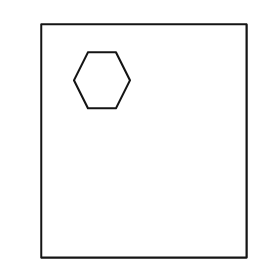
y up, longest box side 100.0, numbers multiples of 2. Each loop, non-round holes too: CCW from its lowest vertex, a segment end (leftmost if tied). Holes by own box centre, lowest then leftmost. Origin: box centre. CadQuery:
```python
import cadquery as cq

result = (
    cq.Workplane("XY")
    .moveTo(-44.0, -50.0)
    .lineTo(44.0, -50.0)
    .lineTo(44.0, 50.0)
    .lineTo(-44.0, 50.0)
    .close()
    .moveTo(-24.0, 14.0)
    .lineTo(-12.0, 14.0)
    .lineTo(-6.0, 26.0)
    .lineTo(-12.0, 38.0)
    .lineTo(-24.0, 38.0)
    .lineTo(-30.0, 26.0)
    .close()
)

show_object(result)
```